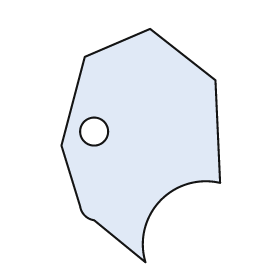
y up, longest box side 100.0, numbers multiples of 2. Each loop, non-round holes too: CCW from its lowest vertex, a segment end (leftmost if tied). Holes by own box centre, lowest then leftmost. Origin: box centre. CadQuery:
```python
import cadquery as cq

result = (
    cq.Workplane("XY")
    .moveTo(2.0, -50.0)
    .threePointArc((8.0, -24.0), (34.0, -16.0))
    .lineTo(32.0, 28.0)
    .lineTo(4.0, 50.0)
    .lineTo(-24.0, 38.0)
    .lineTo(-34.0, 0.0)
    .lineTo(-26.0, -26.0)
    .threePointArc((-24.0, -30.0), (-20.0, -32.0))
    .close()
    .moveTo(-20.0, 6.0)
    .circle(6.0)
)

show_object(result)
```